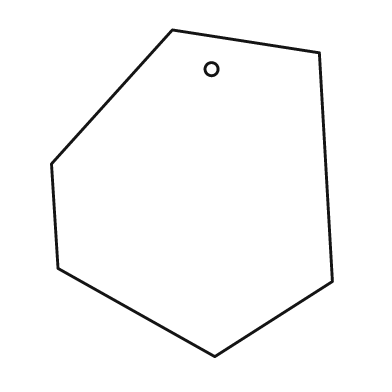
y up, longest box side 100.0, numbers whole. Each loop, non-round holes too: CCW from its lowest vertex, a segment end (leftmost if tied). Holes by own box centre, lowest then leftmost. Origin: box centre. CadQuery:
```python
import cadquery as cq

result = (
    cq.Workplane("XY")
    .moveTo(7.0, -50.0)
    .lineTo(43.0, -27.0)
    .lineTo(39.0, 43.0)
    .lineTo(-6.0, 50.0)
    .lineTo(-43.0, 9.0)
    .lineTo(-41.0, -23.0)
    .close()
    .moveTo(6.0, 38.0)
    .circle(2.0)
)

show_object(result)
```